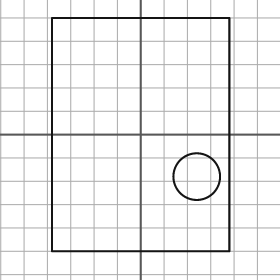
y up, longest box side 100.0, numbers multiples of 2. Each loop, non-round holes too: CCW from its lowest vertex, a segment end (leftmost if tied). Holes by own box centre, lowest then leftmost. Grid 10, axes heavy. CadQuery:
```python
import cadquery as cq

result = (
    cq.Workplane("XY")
    .moveTo(-38.0, -50.0)
    .lineTo(38.0, -50.0)
    .lineTo(38.0, 50.0)
    .lineTo(-38.0, 50.0)
    .close()
    .moveTo(24.0, -18.0)
    .circle(10.0)
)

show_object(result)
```